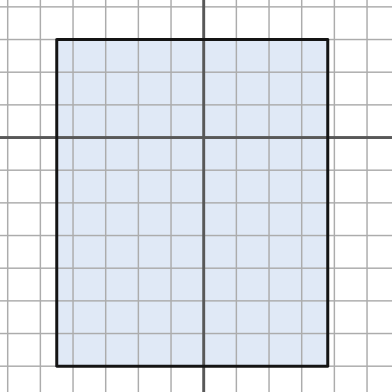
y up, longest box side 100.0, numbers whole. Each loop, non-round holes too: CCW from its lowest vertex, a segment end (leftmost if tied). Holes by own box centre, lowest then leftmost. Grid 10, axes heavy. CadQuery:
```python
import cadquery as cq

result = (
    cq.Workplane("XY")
    .moveTo(-45.0, -70.0)
    .lineTo(38.0, -70.0)
    .lineTo(38.0, 30.0)
    .lineTo(-45.0, 30.0)
    .close()
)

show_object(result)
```